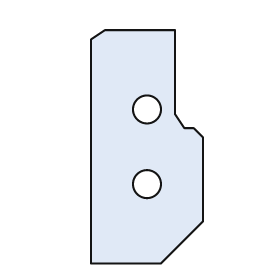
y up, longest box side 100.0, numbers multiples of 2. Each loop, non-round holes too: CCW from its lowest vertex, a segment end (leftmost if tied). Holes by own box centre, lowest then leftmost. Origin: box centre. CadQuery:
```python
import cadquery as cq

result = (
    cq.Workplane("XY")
    .moveTo(-24.0, -50.0)
    .lineTo(6.0, -50.0)
    .lineTo(24.0, -32.0)
    .lineTo(24.0, 4.0)
    .lineTo(20.0, 8.0)
    .lineTo(16.0, 8.0)
    .lineTo(12.0, 14.0)
    .lineTo(12.0, 50.0)
    .lineTo(-18.0, 50.0)
    .lineTo(-24.0, 46.0)
    .close()
    .moveTo(0.0, -16.0)
    .circle(6.0)
    .moveTo(0.0, 16.0)
    .circle(6.0)
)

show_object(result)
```